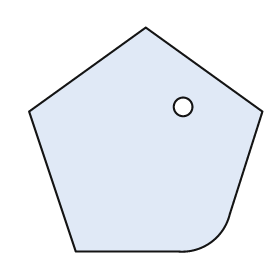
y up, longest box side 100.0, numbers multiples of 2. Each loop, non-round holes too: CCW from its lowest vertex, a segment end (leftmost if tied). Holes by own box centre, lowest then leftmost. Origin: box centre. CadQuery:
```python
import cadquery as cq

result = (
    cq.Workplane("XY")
    .moveTo(-30.0, -48.0)
    .lineTo(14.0, -48.0)
    .threePointArc((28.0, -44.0), (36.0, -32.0))
    .lineTo(50.0, 12.0)
    .lineTo(0.0, 48.0)
    .lineTo(-50.0, 12.0)
    .close()
    .moveTo(16.0, 14.0)
    .circle(4.0)
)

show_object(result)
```